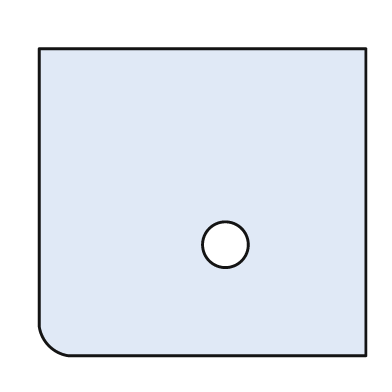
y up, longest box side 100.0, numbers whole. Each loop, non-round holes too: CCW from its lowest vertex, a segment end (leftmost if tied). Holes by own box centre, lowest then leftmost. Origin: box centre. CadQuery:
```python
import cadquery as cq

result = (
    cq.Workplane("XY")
    .moveTo(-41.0, -47.0)
    .lineTo(50.0, -47.0)
    .lineTo(50.0, 47.0)
    .lineTo(-50.0, 47.0)
    .lineTo(-50.0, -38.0)
    .threePointArc((-47.0, -44.0), (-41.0, -47.0))
    .close()
    .moveTo(7.0, -13.0)
    .circle(7.0)
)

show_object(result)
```